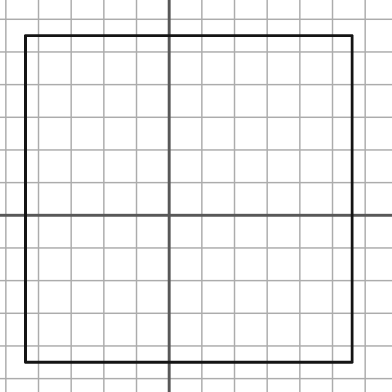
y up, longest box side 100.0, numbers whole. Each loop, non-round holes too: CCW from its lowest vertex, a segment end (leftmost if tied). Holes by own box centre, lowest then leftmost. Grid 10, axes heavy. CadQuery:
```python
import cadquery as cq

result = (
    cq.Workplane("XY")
    .moveTo(-44.0, -45.0)
    .lineTo(56.0, -45.0)
    .lineTo(56.0, 55.0)
    .lineTo(-44.0, 55.0)
    .close()
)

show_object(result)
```